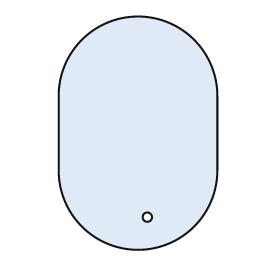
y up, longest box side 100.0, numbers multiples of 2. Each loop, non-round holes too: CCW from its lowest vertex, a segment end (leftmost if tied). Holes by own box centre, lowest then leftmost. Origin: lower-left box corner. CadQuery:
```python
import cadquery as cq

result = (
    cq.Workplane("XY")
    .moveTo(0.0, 34.0)
    .threePointArc((34.0, 0.0), (68.0, 34.0))
    .lineTo(68.0, 66.0)
    .threePointArc((34.0, 100.0), (0.0, 66.0))
    .close()
    .moveTo(38.0, 14.0)
    .circle(2.0)
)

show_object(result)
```